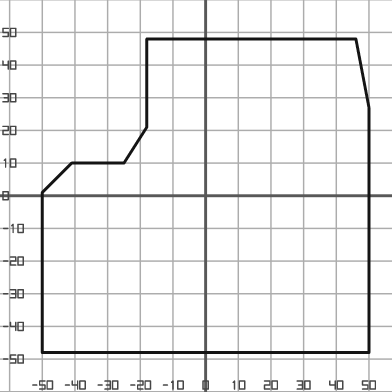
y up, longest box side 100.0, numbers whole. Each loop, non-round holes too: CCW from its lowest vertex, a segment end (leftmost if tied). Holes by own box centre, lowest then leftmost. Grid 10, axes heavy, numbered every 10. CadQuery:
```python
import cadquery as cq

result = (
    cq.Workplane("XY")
    .moveTo(-50.0, -48.0)
    .lineTo(50.0, -48.0)
    .lineTo(50.0, 27.0)
    .lineTo(46.0, 48.0)
    .lineTo(-18.0, 48.0)
    .lineTo(-18.0, 21.0)
    .lineTo(-25.0, 10.0)
    .lineTo(-41.0, 10.0)
    .lineTo(-50.0, 1.0)
    .close()
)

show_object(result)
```